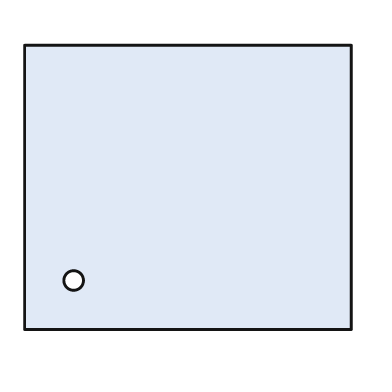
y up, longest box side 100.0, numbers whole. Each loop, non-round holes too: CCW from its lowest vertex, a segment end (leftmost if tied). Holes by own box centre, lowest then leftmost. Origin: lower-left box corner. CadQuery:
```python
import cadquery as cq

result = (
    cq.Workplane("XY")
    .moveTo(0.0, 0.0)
    .lineTo(100.0, 0.0)
    .lineTo(100.0, 87.0)
    .lineTo(0.0, 87.0)
    .close()
    .moveTo(15.0, 15.0)
    .circle(3.0)
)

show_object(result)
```